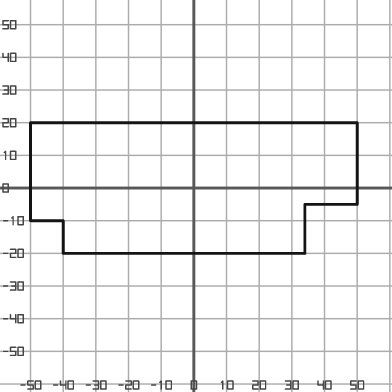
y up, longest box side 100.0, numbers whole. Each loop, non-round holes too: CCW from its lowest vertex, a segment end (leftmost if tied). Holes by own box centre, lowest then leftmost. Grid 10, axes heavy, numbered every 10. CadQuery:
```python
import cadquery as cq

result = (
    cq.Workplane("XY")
    .moveTo(-40.0, -20.0)
    .lineTo(34.0, -20.0)
    .lineTo(34.0, -5.0)
    .lineTo(50.0, -5.0)
    .lineTo(50.0, 20.0)
    .lineTo(-50.0, 20.0)
    .lineTo(-50.0, -10.0)
    .lineTo(-40.0, -10.0)
    .close()
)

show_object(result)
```